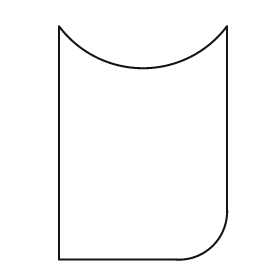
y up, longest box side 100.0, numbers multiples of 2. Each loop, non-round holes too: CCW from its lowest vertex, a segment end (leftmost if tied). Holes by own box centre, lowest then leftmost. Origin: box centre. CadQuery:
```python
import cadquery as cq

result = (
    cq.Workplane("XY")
    .moveTo(-36.0, -50.0)
    .lineTo(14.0, -50.0)
    .threePointArc((30.0, -44.0), (36.0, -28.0))
    .lineTo(36.0, 50.0)
    .threePointArc((0.0, 32.0), (-36.0, 50.0))
    .close()
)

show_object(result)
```